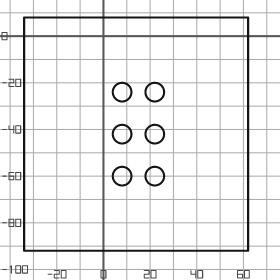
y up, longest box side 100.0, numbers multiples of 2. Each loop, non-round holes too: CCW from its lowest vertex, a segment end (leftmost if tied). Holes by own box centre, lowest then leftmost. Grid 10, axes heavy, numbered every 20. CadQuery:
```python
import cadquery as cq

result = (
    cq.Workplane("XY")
    .moveTo(-34.0, -92.0)
    .lineTo(62.0, -92.0)
    .lineTo(62.0, 8.0)
    .lineTo(-34.0, 8.0)
    .close()
    .moveTo(8.0, -60.0)
    .circle(4.0)
    .moveTo(22.0, -60.0)
    .circle(4.0)
    .moveTo(8.0, -42.0)
    .circle(4.0)
    .moveTo(22.0, -42.0)
    .circle(4.0)
    .moveTo(8.0, -24.0)
    .circle(4.0)
    .moveTo(22.0, -24.0)
    .circle(4.0)
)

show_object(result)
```